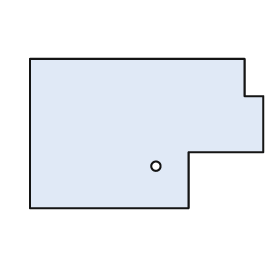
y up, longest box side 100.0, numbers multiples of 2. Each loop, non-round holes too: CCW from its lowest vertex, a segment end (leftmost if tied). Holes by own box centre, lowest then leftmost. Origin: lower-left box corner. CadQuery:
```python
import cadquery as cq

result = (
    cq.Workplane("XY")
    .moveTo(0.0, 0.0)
    .lineTo(68.0, 0.0)
    .lineTo(68.0, 24.0)
    .lineTo(100.0, 24.0)
    .lineTo(100.0, 48.0)
    .lineTo(92.0, 48.0)
    .lineTo(92.0, 64.0)
    .lineTo(0.0, 64.0)
    .close()
    .moveTo(54.0, 18.0)
    .circle(2.0)
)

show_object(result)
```